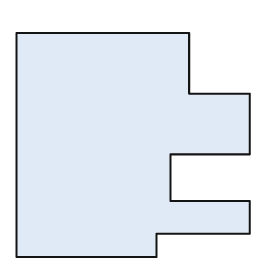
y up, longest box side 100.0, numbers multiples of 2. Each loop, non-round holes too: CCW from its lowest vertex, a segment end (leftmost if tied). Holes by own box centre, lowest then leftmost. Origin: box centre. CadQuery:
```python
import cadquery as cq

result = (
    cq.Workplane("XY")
    .moveTo(-50.0, -48.0)
    .lineTo(10.0, -48.0)
    .lineTo(10.0, -38.0)
    .lineTo(50.0, -38.0)
    .lineTo(50.0, -24.0)
    .lineTo(16.0, -24.0)
    .lineTo(16.0, -4.0)
    .lineTo(50.0, -4.0)
    .lineTo(50.0, 22.0)
    .lineTo(24.0, 22.0)
    .lineTo(24.0, 48.0)
    .lineTo(-50.0, 48.0)
    .close()
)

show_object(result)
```